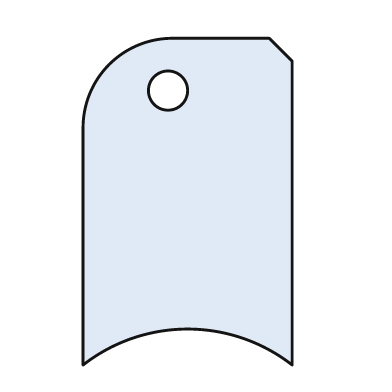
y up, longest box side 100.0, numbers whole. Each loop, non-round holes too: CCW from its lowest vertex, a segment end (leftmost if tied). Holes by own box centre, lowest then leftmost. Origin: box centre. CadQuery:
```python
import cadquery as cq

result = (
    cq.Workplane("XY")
    .moveTo(-32.0, -50.0)
    .threePointArc((0.0, -39.0), (32.0, -50.0))
    .lineTo(32.0, 43.0)
    .lineTo(25.0, 50.0)
    .lineTo(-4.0, 50.0)
    .threePointArc((-24.0, 42.0), (-32.0, 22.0))
    .close()
    .moveTo(-6.0, 34.0)
    .circle(6.0)
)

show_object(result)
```